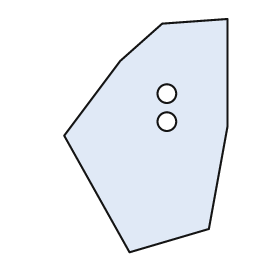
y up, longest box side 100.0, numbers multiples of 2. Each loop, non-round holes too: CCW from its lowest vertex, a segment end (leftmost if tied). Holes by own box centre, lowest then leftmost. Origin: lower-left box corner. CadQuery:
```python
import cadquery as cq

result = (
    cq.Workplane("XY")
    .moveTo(28.0, 0.0)
    .lineTo(62.0, 10.0)
    .lineTo(70.0, 54.0)
    .lineTo(70.0, 100.0)
    .lineTo(42.0, 98.0)
    .lineTo(24.0, 82.0)
    .lineTo(0.0, 50.0)
    .close()
    .moveTo(44.0, 56.0)
    .circle(4.0)
    .moveTo(44.0, 68.0)
    .circle(4.0)
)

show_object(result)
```